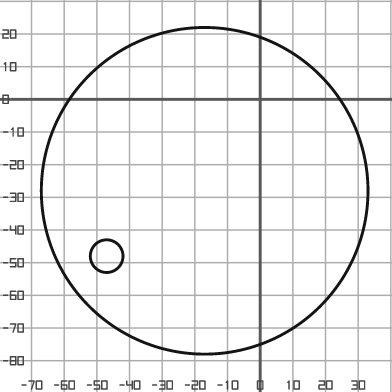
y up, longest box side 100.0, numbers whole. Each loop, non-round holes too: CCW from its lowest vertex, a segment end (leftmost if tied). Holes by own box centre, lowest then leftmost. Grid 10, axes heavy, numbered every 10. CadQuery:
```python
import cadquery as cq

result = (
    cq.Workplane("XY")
    .moveTo(-17.0, -28.0)
    .circle(50.0)
    .moveTo(-47.0, -48.0)
    .circle(5.0)
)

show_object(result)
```